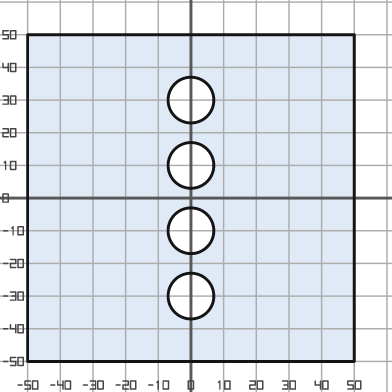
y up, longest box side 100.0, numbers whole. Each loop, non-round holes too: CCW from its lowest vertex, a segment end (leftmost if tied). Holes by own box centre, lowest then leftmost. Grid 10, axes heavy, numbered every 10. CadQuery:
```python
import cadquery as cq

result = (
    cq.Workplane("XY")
    .moveTo(-50.0, -50.0)
    .lineTo(50.0, -50.0)
    .lineTo(50.0, 50.0)
    .lineTo(-50.0, 50.0)
    .close()
    .moveTo(0.0, -30.0)
    .circle(7.0)
    .moveTo(0.0, -10.0)
    .circle(7.0)
    .moveTo(0.0, 10.0)
    .circle(7.0)
    .moveTo(0.0, 30.0)
    .circle(7.0)
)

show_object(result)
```